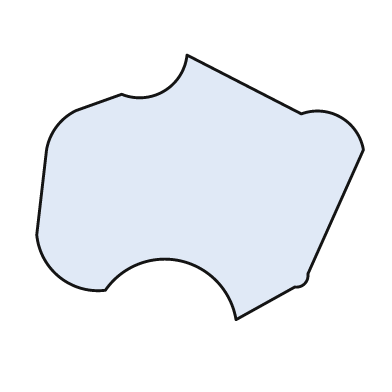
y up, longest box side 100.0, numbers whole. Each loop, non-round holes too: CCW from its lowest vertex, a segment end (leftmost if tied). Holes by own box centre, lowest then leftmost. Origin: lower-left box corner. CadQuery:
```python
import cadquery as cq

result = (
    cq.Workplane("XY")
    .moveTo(61.0, 0.0)
    .lineTo(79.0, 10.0)
    .threePointArc((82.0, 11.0), (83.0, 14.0))
    .lineTo(100.0, 52.0)
    .threePointArc((93.0, 62.0), (81.0, 63.0))
    .lineTo(46.0, 81.0)
    .threePointArc((39.0, 70.0), (26.0, 69.0))
    .lineTo(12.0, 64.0)
    .threePointArc((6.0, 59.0), (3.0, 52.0))
    .lineTo(0.0, 26.0)
    .threePointArc((7.0, 13.0), (21.0, 9.0))
    .threePointArc((44.0, 18.0), (61.0, 0.0))
    .close()
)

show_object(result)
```